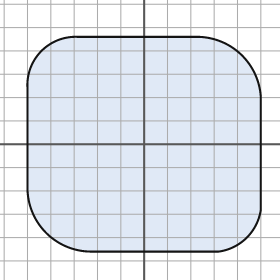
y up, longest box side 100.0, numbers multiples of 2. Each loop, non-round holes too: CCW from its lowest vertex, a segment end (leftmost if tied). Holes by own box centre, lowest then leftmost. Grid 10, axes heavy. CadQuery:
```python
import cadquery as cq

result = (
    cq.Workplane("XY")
    .moveTo(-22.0, -46.0)
    .lineTo(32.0, -46.0)
    .threePointArc((44.0, -40.0), (50.0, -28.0))
    .lineTo(50.0, 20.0)
    .threePointArc((42.0, 38.0), (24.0, 46.0))
    .lineTo(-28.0, 46.0)
    .threePointArc((-44.0, 40.0), (-50.0, 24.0))
    .lineTo(-50.0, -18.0)
    .threePointArc((-42.0, -38.0), (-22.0, -46.0))
    .close()
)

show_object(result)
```